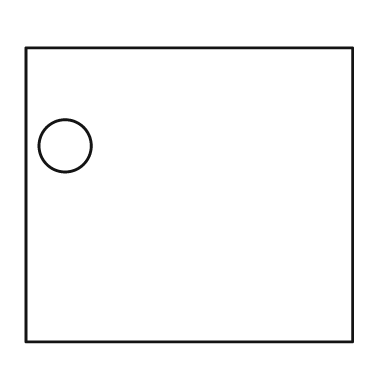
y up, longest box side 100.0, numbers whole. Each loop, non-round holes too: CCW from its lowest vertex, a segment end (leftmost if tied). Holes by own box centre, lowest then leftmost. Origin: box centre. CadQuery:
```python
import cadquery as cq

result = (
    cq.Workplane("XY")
    .moveTo(-50.0, -45.0)
    .lineTo(50.0, -45.0)
    .lineTo(50.0, 45.0)
    .lineTo(-50.0, 45.0)
    .close()
    .moveTo(-38.0, 15.0)
    .circle(8.0)
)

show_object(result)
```